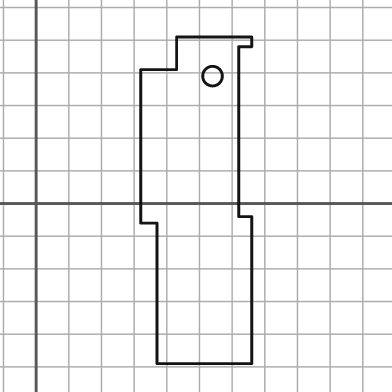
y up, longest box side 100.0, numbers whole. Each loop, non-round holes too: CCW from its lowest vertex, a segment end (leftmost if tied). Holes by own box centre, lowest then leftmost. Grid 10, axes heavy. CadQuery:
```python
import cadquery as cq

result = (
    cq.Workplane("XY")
    .moveTo(37.0, -49.0)
    .lineTo(66.0, -49.0)
    .lineTo(66.0, -4.0)
    .lineTo(62.0, -4.0)
    .lineTo(62.0, 48.0)
    .lineTo(66.0, 48.0)
    .lineTo(66.0, 51.0)
    .lineTo(43.0, 51.0)
    .lineTo(43.0, 41.0)
    .lineTo(32.0, 41.0)
    .lineTo(32.0, -6.0)
    .lineTo(37.0, -6.0)
    .close()
    .moveTo(54.0, 39.0)
    .circle(3.0)
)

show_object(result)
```